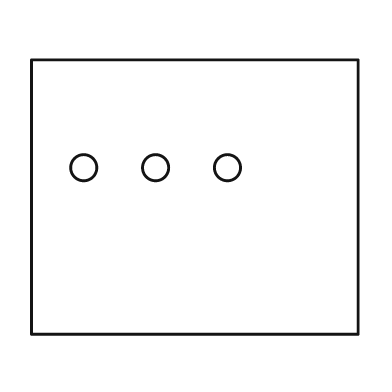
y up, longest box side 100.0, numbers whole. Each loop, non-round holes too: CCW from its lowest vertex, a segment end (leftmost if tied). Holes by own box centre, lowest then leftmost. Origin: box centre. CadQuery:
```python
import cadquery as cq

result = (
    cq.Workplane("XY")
    .moveTo(-50.0, -42.0)
    .lineTo(50.0, -42.0)
    .lineTo(50.0, 42.0)
    .lineTo(-50.0, 42.0)
    .close()
    .moveTo(-34.0, 9.0)
    .circle(4.0)
    .moveTo(-12.0, 9.0)
    .circle(4.0)
    .moveTo(10.0, 9.0)
    .circle(4.0)
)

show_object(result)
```